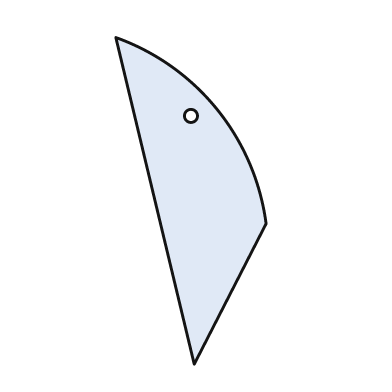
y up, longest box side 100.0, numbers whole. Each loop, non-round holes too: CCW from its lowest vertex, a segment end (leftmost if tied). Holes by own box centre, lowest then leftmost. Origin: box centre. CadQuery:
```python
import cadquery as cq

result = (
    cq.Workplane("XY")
    .moveTo(1.0, -50.0)
    .lineTo(23.0, -7.0)
    .threePointArc((8.0, 28.0), (-23.0, 50.0))
    .close()
    .moveTo(0.0, 26.0)
    .circle(2.0)
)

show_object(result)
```